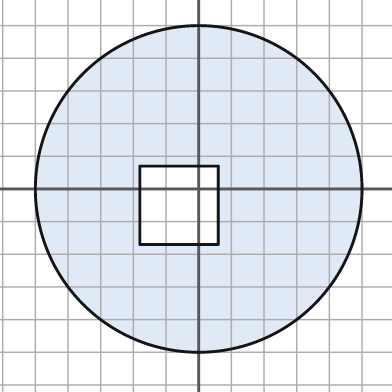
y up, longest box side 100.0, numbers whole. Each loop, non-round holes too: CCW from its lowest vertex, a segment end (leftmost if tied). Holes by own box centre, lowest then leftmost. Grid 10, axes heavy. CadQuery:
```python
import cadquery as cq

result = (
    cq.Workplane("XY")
    .moveTo(0.0, 0.0)
    .circle(50.0)
    .moveTo(-18.0, -17.0)
    .lineTo(6.0, -17.0)
    .lineTo(6.0, 7.0)
    .lineTo(-18.0, 7.0)
    .close()
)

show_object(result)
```